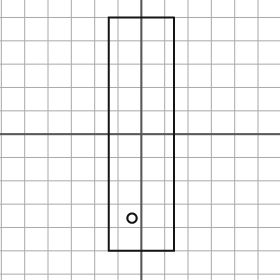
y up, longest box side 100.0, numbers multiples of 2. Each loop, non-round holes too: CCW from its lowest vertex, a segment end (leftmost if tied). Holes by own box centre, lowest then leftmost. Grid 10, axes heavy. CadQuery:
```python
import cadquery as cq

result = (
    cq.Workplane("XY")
    .moveTo(-14.0, -50.0)
    .lineTo(14.0, -50.0)
    .lineTo(14.0, 50.0)
    .lineTo(-14.0, 50.0)
    .close()
    .moveTo(-4.0, -36.0)
    .circle(2.0)
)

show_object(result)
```